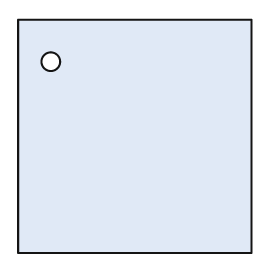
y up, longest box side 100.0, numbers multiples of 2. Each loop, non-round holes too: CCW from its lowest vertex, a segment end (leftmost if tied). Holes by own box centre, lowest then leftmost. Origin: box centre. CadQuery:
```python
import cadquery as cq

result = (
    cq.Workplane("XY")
    .moveTo(-50.0, -50.0)
    .lineTo(50.0, -50.0)
    .lineTo(50.0, 50.0)
    .lineTo(-50.0, 50.0)
    .close()
    .moveTo(-36.0, 32.0)
    .circle(4.0)
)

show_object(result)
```